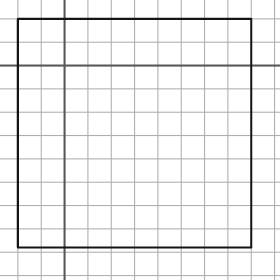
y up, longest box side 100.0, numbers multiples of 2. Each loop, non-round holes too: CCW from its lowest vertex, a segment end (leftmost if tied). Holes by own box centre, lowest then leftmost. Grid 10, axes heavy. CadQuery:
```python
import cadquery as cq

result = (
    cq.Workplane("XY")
    .moveTo(-20.0, -78.0)
    .lineTo(80.0, -78.0)
    .lineTo(80.0, 20.0)
    .lineTo(-20.0, 20.0)
    .close()
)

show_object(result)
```